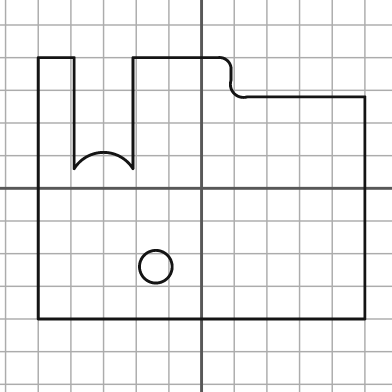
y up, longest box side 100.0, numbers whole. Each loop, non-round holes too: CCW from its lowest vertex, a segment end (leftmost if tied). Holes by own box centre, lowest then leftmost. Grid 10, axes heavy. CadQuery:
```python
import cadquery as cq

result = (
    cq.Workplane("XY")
    .moveTo(-50.0, -40.0)
    .lineTo(50.0, -40.0)
    .lineTo(50.0, 28.0)
    .lineTo(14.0, 28.0)
    .threePointArc((10.0, 29.0), (9.0, 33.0))
    .lineTo(9.0, 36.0)
    .threePointArc((8.0, 39.0), (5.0, 40.0))
    .lineTo(-21.0, 40.0)
    .lineTo(-21.0, 6.0)
    .threePointArc((-30.0, 11.0), (-39.0, 6.0))
    .lineTo(-39.0, 40.0)
    .lineTo(-50.0, 40.0)
    .close()
    .moveTo(-14.0, -24.0)
    .circle(5.0)
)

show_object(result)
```